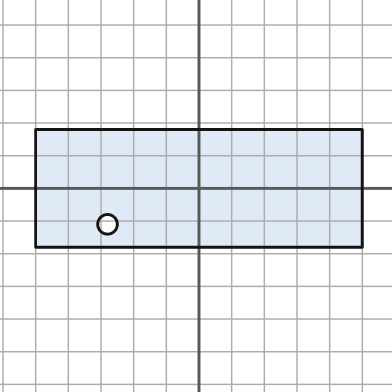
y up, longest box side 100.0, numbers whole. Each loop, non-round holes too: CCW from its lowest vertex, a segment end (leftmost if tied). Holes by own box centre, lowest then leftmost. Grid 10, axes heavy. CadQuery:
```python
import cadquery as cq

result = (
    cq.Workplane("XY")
    .moveTo(-50.0, -18.0)
    .lineTo(50.0, -18.0)
    .lineTo(50.0, 18.0)
    .lineTo(-50.0, 18.0)
    .close()
    .moveTo(-28.0, -11.0)
    .circle(3.0)
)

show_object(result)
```